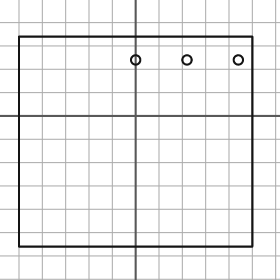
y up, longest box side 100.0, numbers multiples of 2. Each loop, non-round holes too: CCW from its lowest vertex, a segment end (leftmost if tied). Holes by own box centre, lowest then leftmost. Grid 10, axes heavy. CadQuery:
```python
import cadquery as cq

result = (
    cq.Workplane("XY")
    .moveTo(-50.0, -56.0)
    .lineTo(50.0, -56.0)
    .lineTo(50.0, 34.0)
    .lineTo(-50.0, 34.0)
    .close()
    .moveTo(0.0, 24.0)
    .circle(2.0)
    .moveTo(22.0, 24.0)
    .circle(2.0)
    .moveTo(44.0, 24.0)
    .circle(2.0)
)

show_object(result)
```